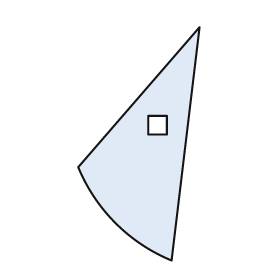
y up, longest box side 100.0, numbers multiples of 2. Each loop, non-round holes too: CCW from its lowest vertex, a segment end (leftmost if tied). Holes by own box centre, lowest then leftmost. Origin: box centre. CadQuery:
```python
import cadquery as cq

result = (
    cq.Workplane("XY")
    .moveTo(14.0, -50.0)
    .lineTo(26.0, 50.0)
    .lineTo(-26.0, -10.0)
    .threePointArc((-10.0, -34.0), (14.0, -50.0))
    .close()
    .moveTo(4.0, 4.0)
    .lineTo(12.0, 4.0)
    .lineTo(12.0, 12.0)
    .lineTo(4.0, 12.0)
    .close()
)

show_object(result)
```